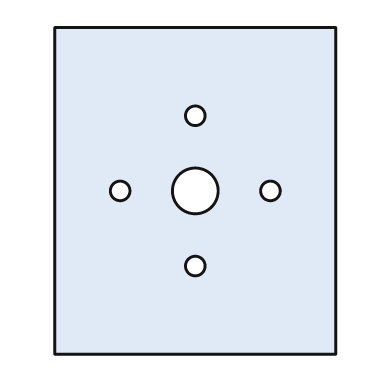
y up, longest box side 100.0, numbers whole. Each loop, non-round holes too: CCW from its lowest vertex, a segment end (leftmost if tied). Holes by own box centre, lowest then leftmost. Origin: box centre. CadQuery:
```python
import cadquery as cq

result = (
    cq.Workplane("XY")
    .moveTo(-43.0, -50.0)
    .lineTo(43.0, -50.0)
    .lineTo(43.0, 50.0)
    .lineTo(-43.0, 50.0)
    .close()
    .moveTo(0.0, -23.0)
    .circle(3.0)
    .moveTo(-23.0, 0.0)
    .circle(3.0)
    .moveTo(0.0, 0.0)
    .circle(7.0)
    .moveTo(23.0, 0.0)
    .circle(3.0)
    .moveTo(0.0, 23.0)
    .circle(3.0)
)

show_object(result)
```